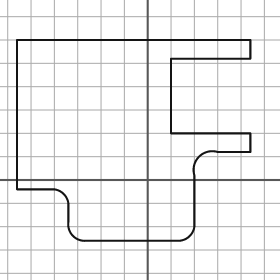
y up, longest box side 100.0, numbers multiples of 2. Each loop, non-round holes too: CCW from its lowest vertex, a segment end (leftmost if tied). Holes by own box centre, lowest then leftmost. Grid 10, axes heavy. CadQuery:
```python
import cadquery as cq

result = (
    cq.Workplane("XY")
    .moveTo(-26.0, -26.0)
    .lineTo(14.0, -26.0)
    .threePointArc((18.0, -24.0), (20.0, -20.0))
    .lineTo(20.0, 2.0)
    .threePointArc((22.0, 10.0), (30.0, 12.0))
    .lineTo(44.0, 12.0)
    .lineTo(44.0, 20.0)
    .lineTo(10.0, 20.0)
    .lineTo(10.0, 52.0)
    .lineTo(44.0, 52.0)
    .lineTo(44.0, 60.0)
    .lineTo(-56.0, 60.0)
    .lineTo(-56.0, -4.0)
    .lineTo(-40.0, -4.0)
    .threePointArc((-36.0, -6.0), (-34.0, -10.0))
    .lineTo(-34.0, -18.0)
    .threePointArc((-32.0, -24.0), (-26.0, -26.0))
    .close()
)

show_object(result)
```